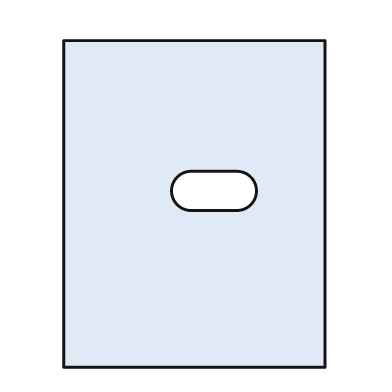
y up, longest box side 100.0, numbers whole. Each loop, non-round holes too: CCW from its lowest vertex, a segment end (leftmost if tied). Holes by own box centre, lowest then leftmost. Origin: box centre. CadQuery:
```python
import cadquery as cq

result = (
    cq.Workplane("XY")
    .moveTo(-40.0, -50.0)
    .lineTo(40.0, -50.0)
    .lineTo(40.0, 50.0)
    .lineTo(-40.0, 50.0)
    .close()
    .moveTo(-1.0, -2.0)
    .lineTo(13.0, -2.0)
    .threePointArc((19.0, 4.0), (13.0, 10.0))
    .lineTo(-1.0, 10.0)
    .threePointArc((-7.0, 4.0), (-1.0, -2.0))
    .close()
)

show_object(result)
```